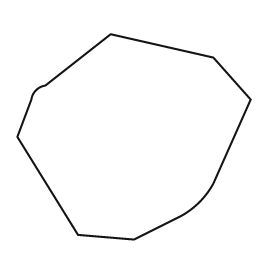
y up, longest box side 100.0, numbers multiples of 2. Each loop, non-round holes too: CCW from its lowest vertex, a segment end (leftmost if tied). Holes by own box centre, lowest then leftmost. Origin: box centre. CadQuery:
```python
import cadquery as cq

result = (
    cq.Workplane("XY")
    .moveTo(0.0, -44.0)
    .lineTo(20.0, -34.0)
    .threePointArc((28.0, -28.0), (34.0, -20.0))
    .lineTo(50.0, 16.0)
    .lineTo(34.0, 34.0)
    .lineTo(-10.0, 44.0)
    .lineTo(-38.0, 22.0)
    .threePointArc((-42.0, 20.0), (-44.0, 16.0))
    .lineTo(-50.0, 0.0)
    .lineTo(-24.0, -42.0)
    .close()
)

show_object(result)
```